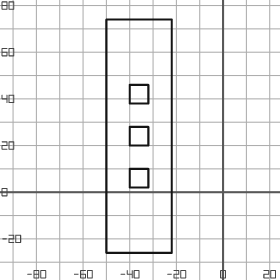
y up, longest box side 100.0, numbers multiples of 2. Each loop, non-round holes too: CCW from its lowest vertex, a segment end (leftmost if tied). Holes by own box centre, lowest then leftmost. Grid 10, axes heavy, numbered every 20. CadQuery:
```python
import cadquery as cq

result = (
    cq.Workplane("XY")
    .moveTo(-50.0, -26.0)
    .lineTo(-22.0, -26.0)
    .lineTo(-22.0, 74.0)
    .lineTo(-50.0, 74.0)
    .close()
    .moveTo(-40.0, 2.0)
    .lineTo(-32.0, 2.0)
    .lineTo(-32.0, 10.0)
    .lineTo(-40.0, 10.0)
    .close()
    .moveTo(-40.0, 20.0)
    .lineTo(-32.0, 20.0)
    .lineTo(-32.0, 28.0)
    .lineTo(-40.0, 28.0)
    .close()
    .moveTo(-40.0, 38.0)
    .lineTo(-32.0, 38.0)
    .lineTo(-32.0, 46.0)
    .lineTo(-40.0, 46.0)
    .close()
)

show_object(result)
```